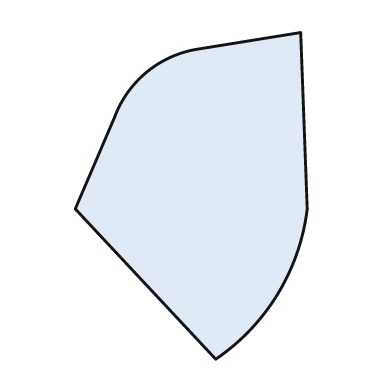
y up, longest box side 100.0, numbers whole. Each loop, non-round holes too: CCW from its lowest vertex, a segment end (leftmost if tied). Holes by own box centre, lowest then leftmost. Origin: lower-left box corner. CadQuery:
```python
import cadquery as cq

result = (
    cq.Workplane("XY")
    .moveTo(43.0, 0.0)
    .threePointArc((62.0, 20.0), (71.0, 46.0))
    .lineTo(69.0, 100.0)
    .lineTo(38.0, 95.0)
    .threePointArc((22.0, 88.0), (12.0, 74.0))
    .lineTo(0.0, 46.0)
    .close()
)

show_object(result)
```